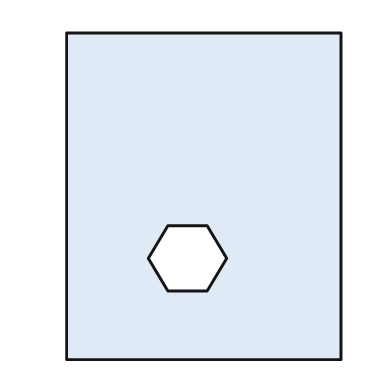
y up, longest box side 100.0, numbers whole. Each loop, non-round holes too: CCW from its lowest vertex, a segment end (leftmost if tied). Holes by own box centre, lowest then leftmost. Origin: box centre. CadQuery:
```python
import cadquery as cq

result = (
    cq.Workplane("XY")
    .moveTo(-42.0, -50.0)
    .lineTo(42.0, -50.0)
    .lineTo(42.0, 50.0)
    .lineTo(-42.0, 50.0)
    .close()
    .moveTo(-11.0, -29.0)
    .lineTo(1.0, -29.0)
    .lineTo(7.0, -19.0)
    .lineTo(1.0, -9.0)
    .lineTo(-11.0, -9.0)
    .lineTo(-17.0, -19.0)
    .close()
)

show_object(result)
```